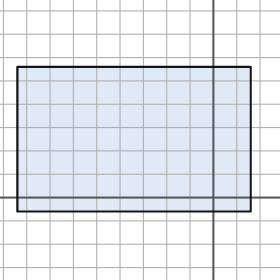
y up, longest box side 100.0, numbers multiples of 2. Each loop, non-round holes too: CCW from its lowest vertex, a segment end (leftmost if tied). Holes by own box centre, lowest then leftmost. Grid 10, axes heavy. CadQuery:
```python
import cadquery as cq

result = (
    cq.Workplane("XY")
    .moveTo(-84.0, -6.0)
    .lineTo(16.0, -6.0)
    .lineTo(16.0, 56.0)
    .lineTo(-84.0, 56.0)
    .close()
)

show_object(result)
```